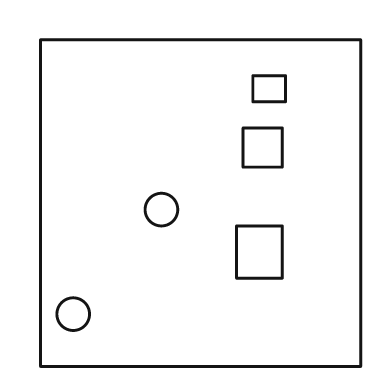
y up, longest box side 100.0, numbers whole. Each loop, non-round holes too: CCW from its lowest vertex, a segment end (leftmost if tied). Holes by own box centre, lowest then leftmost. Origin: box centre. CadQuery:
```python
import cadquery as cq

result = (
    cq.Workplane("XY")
    .moveTo(-49.0, -50.0)
    .lineTo(49.0, -50.0)
    .lineTo(49.0, 50.0)
    .lineTo(-49.0, 50.0)
    .close()
    .moveTo(-39.0, -34.0)
    .circle(5.0)
    .moveTo(11.0, -23.0)
    .lineTo(25.0, -23.0)
    .lineTo(25.0, -7.0)
    .lineTo(11.0, -7.0)
    .close()
    .moveTo(-12.0, -2.0)
    .circle(5.0)
    .moveTo(13.0, 11.0)
    .lineTo(25.0, 11.0)
    .lineTo(25.0, 23.0)
    .lineTo(13.0, 23.0)
    .close()
    .moveTo(16.0, 31.0)
    .lineTo(26.0, 31.0)
    .lineTo(26.0, 39.0)
    .lineTo(16.0, 39.0)
    .close()
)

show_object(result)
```